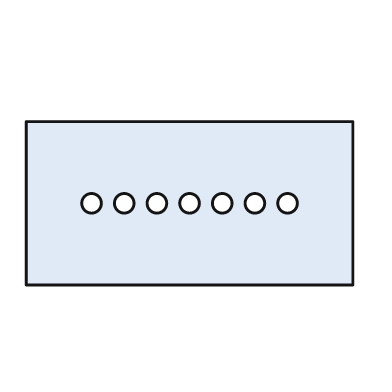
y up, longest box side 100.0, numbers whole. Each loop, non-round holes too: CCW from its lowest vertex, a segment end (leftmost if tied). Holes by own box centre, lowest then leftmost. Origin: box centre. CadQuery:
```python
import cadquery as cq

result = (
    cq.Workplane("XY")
    .moveTo(-50.0, -25.0)
    .lineTo(50.0, -25.0)
    .lineTo(50.0, 25.0)
    .lineTo(-50.0, 25.0)
    .close()
    .moveTo(-30.0, 0.0)
    .circle(3.0)
    .moveTo(-20.0, 0.0)
    .circle(3.0)
    .moveTo(-10.0, 0.0)
    .circle(3.0)
    .moveTo(0.0, 0.0)
    .circle(3.0)
    .moveTo(10.0, 0.0)
    .circle(3.0)
    .moveTo(20.0, 0.0)
    .circle(3.0)
    .moveTo(30.0, 0.0)
    .circle(3.0)
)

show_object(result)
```